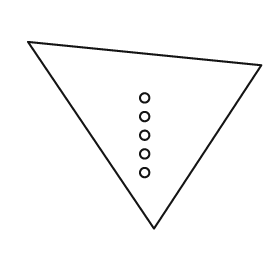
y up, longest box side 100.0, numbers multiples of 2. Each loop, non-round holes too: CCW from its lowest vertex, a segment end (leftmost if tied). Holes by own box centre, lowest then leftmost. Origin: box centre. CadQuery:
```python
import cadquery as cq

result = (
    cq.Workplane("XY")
    .moveTo(4.0, -40.0)
    .lineTo(50.0, 30.0)
    .lineTo(-50.0, 40.0)
    .close()
    .moveTo(0.0, -16.0)
    .circle(2.0)
    .moveTo(0.0, -8.0)
    .circle(2.0)
    .moveTo(0.0, 0.0)
    .circle(2.0)
    .moveTo(0.0, 8.0)
    .circle(2.0)
    .moveTo(0.0, 16.0)
    .circle(2.0)
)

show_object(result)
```